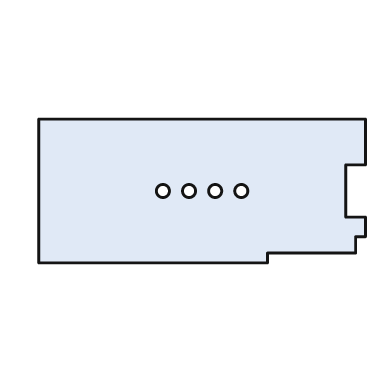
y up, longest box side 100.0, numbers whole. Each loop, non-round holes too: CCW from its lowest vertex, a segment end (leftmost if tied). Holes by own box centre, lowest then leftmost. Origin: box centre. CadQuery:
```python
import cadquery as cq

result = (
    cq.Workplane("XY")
    .moveTo(-50.0, -22.0)
    .lineTo(20.0, -22.0)
    .lineTo(20.0, -19.0)
    .lineTo(47.0, -19.0)
    .lineTo(47.0, -14.0)
    .lineTo(50.0, -14.0)
    .lineTo(50.0, -8.0)
    .lineTo(44.0, -8.0)
    .lineTo(44.0, 8.0)
    .lineTo(50.0, 8.0)
    .lineTo(50.0, 22.0)
    .lineTo(-50.0, 22.0)
    .close()
    .moveTo(-12.0, 0.0)
    .circle(2.0)
    .moveTo(-4.0, 0.0)
    .circle(2.0)
    .moveTo(4.0, 0.0)
    .circle(2.0)
    .moveTo(12.0, 0.0)
    .circle(2.0)
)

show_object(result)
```